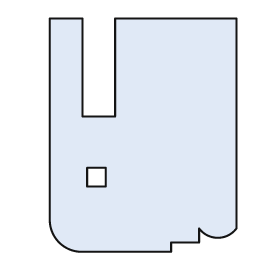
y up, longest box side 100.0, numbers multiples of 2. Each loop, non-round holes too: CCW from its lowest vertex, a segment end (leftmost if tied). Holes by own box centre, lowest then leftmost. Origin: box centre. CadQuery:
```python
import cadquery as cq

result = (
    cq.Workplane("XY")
    .moveTo(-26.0, -50.0)
    .lineTo(12.0, -50.0)
    .lineTo(12.0, -46.0)
    .lineTo(24.0, -46.0)
    .lineTo(24.0, -40.0)
    .threePointArc((32.0, -44.0), (40.0, -40.0))
    .lineTo(40.0, 50.0)
    .lineTo(-12.0, 50.0)
    .lineTo(-12.0, 8.0)
    .lineTo(-26.0, 8.0)
    .lineTo(-26.0, 50.0)
    .lineTo(-40.0, 50.0)
    .lineTo(-40.0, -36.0)
    .threePointArc((-36.0, -46.0), (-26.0, -50.0))
    .close()
    .moveTo(-24.0, -22.0)
    .lineTo(-16.0, -22.0)
    .lineTo(-16.0, -14.0)
    .lineTo(-24.0, -14.0)
    .close()
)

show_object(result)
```